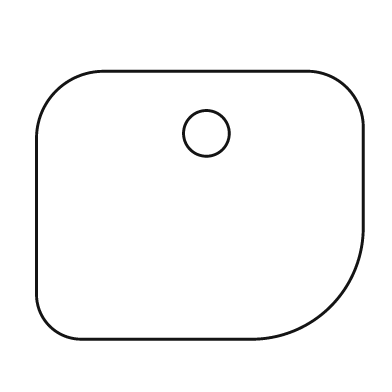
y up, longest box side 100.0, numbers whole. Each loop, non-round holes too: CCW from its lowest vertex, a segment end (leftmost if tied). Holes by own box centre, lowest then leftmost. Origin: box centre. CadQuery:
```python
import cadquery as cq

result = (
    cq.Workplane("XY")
    .moveTo(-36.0, -41.0)
    .lineTo(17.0, -41.0)
    .threePointArc((40.0, -31.0), (50.0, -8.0))
    .lineTo(50.0, 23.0)
    .threePointArc((45.0, 36.0), (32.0, 41.0))
    .lineTo(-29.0, 41.0)
    .threePointArc((-44.0, 35.0), (-50.0, 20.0))
    .lineTo(-50.0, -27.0)
    .threePointArc((-46.0, -37.0), (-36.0, -41.0))
    .close()
    .moveTo(2.0, 22.0)
    .circle(7.0)
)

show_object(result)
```